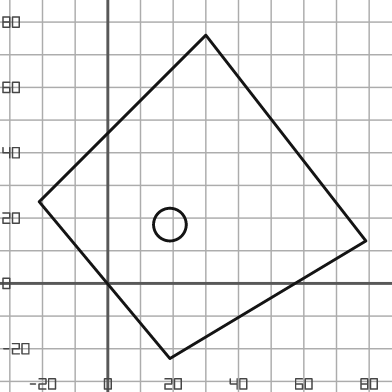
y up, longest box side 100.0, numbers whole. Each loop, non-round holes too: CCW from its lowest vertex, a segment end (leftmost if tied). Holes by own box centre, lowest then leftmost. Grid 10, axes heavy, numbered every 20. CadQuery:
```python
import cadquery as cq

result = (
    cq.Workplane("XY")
    .moveTo(19.0, -23.0)
    .lineTo(79.0, 13.0)
    .lineTo(30.0, 76.0)
    .lineTo(-21.0, 25.0)
    .close()
    .moveTo(19.0, 18.0)
    .circle(5.0)
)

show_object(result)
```